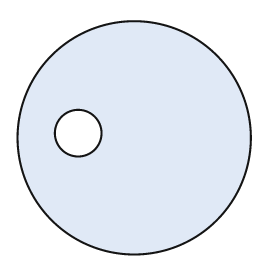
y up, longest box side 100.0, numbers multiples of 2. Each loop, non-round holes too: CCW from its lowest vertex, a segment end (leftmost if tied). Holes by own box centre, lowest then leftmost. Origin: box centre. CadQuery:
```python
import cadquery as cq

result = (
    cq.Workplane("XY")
    .moveTo(0.0, 0.0)
    .circle(50.0)
    .moveTo(-24.0, 2.0)
    .circle(10.0)
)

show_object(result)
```